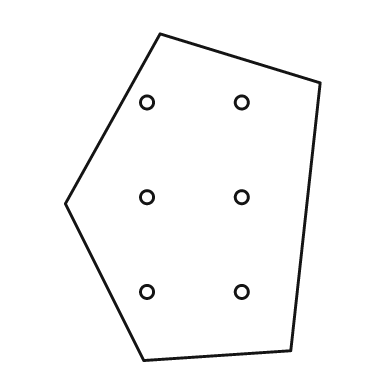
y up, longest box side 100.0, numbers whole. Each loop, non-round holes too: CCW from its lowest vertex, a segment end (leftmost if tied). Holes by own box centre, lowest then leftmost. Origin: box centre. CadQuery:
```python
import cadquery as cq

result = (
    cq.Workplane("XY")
    .moveTo(-15.0, -50.0)
    .lineTo(30.0, -47.0)
    .lineTo(39.0, 35.0)
    .lineTo(-10.0, 50.0)
    .lineTo(-39.0, -2.0)
    .close()
    .moveTo(-14.0, -29.0)
    .circle(2.0)
    .moveTo(15.0, -29.0)
    .circle(2.0)
    .moveTo(-14.0, 0.0)
    .circle(2.0)
    .moveTo(15.0, 0.0)
    .circle(2.0)
    .moveTo(-14.0, 29.0)
    .circle(2.0)
    .moveTo(15.0, 29.0)
    .circle(2.0)
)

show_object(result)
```